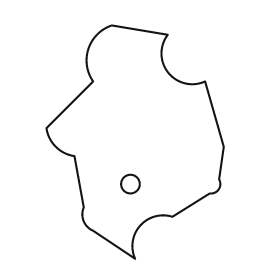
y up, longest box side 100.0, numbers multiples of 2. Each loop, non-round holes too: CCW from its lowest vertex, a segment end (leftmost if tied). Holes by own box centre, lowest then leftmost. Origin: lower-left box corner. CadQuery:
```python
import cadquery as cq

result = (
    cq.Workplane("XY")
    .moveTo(38.0, 0.0)
    .threePointArc((40.0, 14.0), (54.0, 18.0))
    .lineTo(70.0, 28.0)
    .threePointArc((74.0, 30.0), (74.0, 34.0))
    .lineTo(76.0, 48.0)
    .lineTo(68.0, 76.0)
    .threePointArc((52.0, 80.0), (52.0, 96.0))
    .lineTo(28.0, 100.0)
    .threePointArc((18.0, 90.0), (20.0, 76.0))
    .lineTo(0.0, 56.0)
    .threePointArc((4.0, 48.0), (12.0, 44.0))
    .lineTo(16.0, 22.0)
    .threePointArc((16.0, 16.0), (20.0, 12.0))
    .close()
    .moveTo(36.0, 32.0)
    .circle(4.0)
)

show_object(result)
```